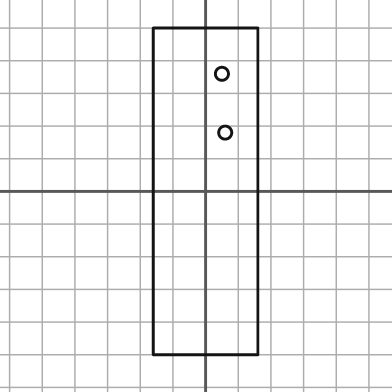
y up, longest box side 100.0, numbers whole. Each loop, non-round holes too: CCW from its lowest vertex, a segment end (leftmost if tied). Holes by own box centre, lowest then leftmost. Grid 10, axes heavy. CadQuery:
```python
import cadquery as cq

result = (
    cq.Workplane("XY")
    .moveTo(-16.0, -50.0)
    .lineTo(16.0, -50.0)
    .lineTo(16.0, 50.0)
    .lineTo(-16.0, 50.0)
    .close()
    .moveTo(6.0, 18.0)
    .circle(2.0)
    .moveTo(5.0, 36.0)
    .circle(2.0)
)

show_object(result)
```